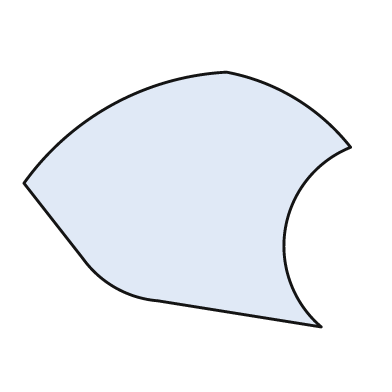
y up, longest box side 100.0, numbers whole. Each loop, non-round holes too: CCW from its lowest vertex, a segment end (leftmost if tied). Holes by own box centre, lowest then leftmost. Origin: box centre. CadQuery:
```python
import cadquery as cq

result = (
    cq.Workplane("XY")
    .moveTo(41.0, -39.0)
    .threePointArc((30.0, -9.0), (50.0, 16.0))
    .threePointArc((33.0, 31.0), (12.0, 39.0))
    .threePointArc((-23.0, 29.0), (-50.0, 5.0))
    .lineTo(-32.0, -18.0)
    .threePointArc((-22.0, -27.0), (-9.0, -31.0))
    .close()
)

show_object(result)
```